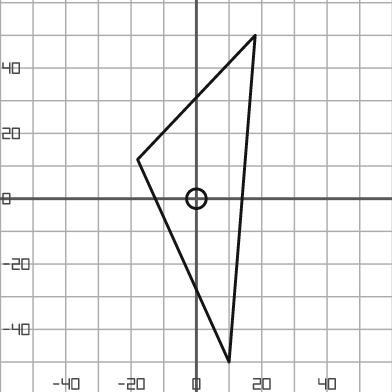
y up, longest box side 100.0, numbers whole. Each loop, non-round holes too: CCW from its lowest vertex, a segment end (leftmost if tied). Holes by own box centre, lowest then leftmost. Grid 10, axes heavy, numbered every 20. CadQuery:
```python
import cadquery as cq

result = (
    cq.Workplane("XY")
    .moveTo(10.0, -50.0)
    .lineTo(18.0, 50.0)
    .lineTo(-18.0, 12.0)
    .close()
    .moveTo(0.0, 0.0)
    .circle(3.0)
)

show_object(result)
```